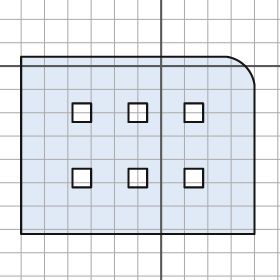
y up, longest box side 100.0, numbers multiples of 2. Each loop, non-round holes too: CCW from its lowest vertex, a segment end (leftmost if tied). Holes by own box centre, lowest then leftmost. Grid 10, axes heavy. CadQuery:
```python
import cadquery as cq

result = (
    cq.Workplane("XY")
    .moveTo(-60.0, -72.0)
    .lineTo(40.0, -72.0)
    .lineTo(40.0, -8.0)
    .threePointArc((36.0, 0.0), (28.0, 4.0))
    .lineTo(-60.0, 4.0)
    .close()
    .moveTo(-38.0, -52.0)
    .lineTo(-30.0, -52.0)
    .lineTo(-30.0, -44.0)
    .lineTo(-38.0, -44.0)
    .close()
    .moveTo(-14.0, -52.0)
    .lineTo(-6.0, -52.0)
    .lineTo(-6.0, -44.0)
    .lineTo(-14.0, -44.0)
    .close()
    .moveTo(10.0, -52.0)
    .lineTo(18.0, -52.0)
    .lineTo(18.0, -44.0)
    .lineTo(10.0, -44.0)
    .close()
    .moveTo(-38.0, -24.0)
    .lineTo(-30.0, -24.0)
    .lineTo(-30.0, -16.0)
    .lineTo(-38.0, -16.0)
    .close()
    .moveTo(-14.0, -24.0)
    .lineTo(-6.0, -24.0)
    .lineTo(-6.0, -16.0)
    .lineTo(-14.0, -16.0)
    .close()
    .moveTo(10.0, -24.0)
    .lineTo(18.0, -24.0)
    .lineTo(18.0, -16.0)
    .lineTo(10.0, -16.0)
    .close()
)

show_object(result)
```